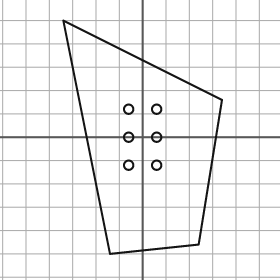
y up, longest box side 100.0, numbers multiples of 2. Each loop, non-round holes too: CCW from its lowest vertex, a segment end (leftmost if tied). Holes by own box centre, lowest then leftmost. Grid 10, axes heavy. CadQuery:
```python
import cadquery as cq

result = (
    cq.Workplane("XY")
    .moveTo(-14.0, -50.0)
    .lineTo(24.0, -46.0)
    .lineTo(34.0, 16.0)
    .lineTo(-34.0, 50.0)
    .close()
    .moveTo(-6.0, -12.0)
    .circle(2.0)
    .moveTo(6.0, -12.0)
    .circle(2.0)
    .moveTo(-6.0, 0.0)
    .circle(2.0)
    .moveTo(6.0, 0.0)
    .circle(2.0)
    .moveTo(-6.0, 12.0)
    .circle(2.0)
    .moveTo(6.0, 12.0)
    .circle(2.0)
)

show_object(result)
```